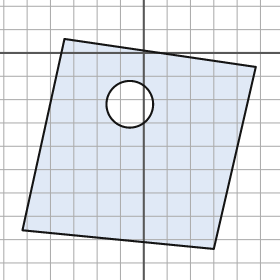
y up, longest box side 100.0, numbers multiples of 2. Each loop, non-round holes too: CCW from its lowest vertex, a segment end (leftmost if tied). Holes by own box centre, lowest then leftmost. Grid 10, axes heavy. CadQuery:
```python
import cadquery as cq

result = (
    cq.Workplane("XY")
    .moveTo(30.0, -84.0)
    .lineTo(48.0, -6.0)
    .lineTo(-34.0, 6.0)
    .lineTo(-52.0, -76.0)
    .close()
    .moveTo(-6.0, -22.0)
    .circle(10.0)
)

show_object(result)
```